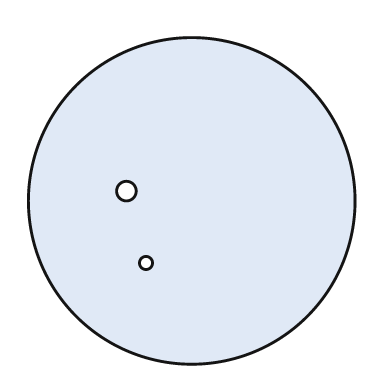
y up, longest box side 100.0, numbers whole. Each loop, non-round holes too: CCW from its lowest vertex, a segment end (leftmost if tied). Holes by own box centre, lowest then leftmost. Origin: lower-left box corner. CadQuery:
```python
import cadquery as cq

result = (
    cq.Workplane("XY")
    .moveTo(50.0, 50.0)
    .circle(50.0)
    .moveTo(36.0, 31.0)
    .circle(2.0)
    .moveTo(30.0, 53.0)
    .circle(3.0)
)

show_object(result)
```